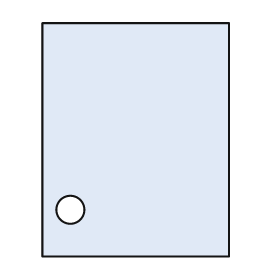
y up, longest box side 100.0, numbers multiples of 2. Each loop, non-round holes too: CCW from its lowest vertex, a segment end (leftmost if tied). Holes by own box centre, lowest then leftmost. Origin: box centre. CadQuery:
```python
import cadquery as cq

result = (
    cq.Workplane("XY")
    .moveTo(-40.0, -50.0)
    .lineTo(40.0, -50.0)
    .lineTo(40.0, 50.0)
    .lineTo(-40.0, 50.0)
    .close()
    .moveTo(-28.0, -30.0)
    .circle(6.0)
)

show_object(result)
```